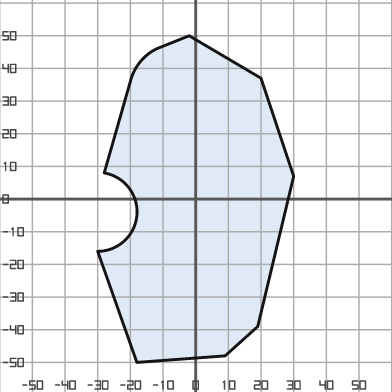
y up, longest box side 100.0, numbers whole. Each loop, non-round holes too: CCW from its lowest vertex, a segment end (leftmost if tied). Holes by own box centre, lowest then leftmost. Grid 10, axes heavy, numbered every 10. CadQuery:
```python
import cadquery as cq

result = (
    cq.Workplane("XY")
    .moveTo(-18.0, -50.0)
    .lineTo(9.0, -48.0)
    .lineTo(19.0, -39.0)
    .lineTo(30.0, 7.0)
    .lineTo(20.0, 37.0)
    .lineTo(-2.0, 50.0)
    .lineTo(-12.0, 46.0)
    .threePointArc((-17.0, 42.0), (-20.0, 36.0))
    .lineTo(-28.0, 8.0)
    .threePointArc((-18.0, -5.0), (-30.0, -16.0))
    .close()
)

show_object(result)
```